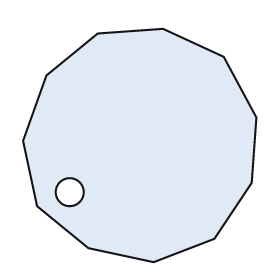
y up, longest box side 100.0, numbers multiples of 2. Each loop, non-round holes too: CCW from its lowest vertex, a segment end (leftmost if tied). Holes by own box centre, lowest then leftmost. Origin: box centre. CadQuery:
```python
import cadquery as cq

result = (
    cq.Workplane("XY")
    .moveTo(6.0, -50.0)
    .lineTo(32.0, -40.0)
    .lineTo(48.0, -16.0)
    .lineTo(50.0, 12.0)
    .lineTo(36.0, 38.0)
    .lineTo(10.0, 50.0)
    .lineTo(-18.0, 48.0)
    .lineTo(-40.0, 30.0)
    .lineTo(-50.0, 2.0)
    .lineTo(-44.0, -26.0)
    .lineTo(-22.0, -44.0)
    .close()
    .moveTo(-30.0, -20.0)
    .circle(6.0)
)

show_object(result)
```